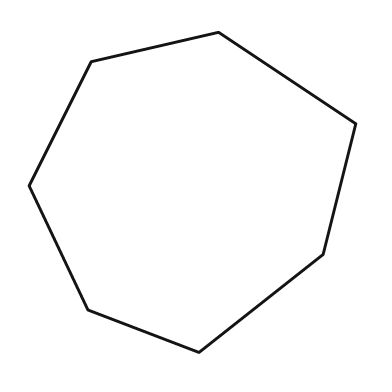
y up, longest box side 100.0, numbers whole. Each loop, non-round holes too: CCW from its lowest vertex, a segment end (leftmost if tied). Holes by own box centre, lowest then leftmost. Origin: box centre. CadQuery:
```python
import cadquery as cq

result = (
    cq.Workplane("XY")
    .moveTo(2.0, -49.0)
    .lineTo(40.0, -19.0)
    .lineTo(50.0, 21.0)
    .lineTo(8.0, 49.0)
    .lineTo(-31.0, 40.0)
    .lineTo(-50.0, 2.0)
    .lineTo(-32.0, -36.0)
    .close()
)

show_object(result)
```